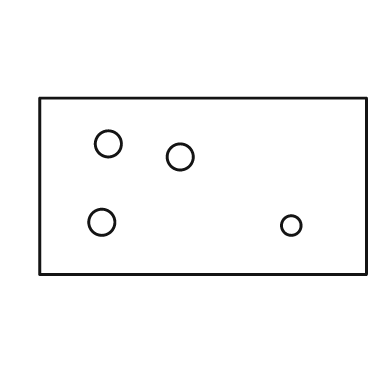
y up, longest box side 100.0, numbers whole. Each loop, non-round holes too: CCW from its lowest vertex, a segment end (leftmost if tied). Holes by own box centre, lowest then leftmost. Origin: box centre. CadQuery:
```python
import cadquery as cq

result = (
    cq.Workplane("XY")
    .moveTo(-50.0, -27.0)
    .lineTo(50.0, -27.0)
    .lineTo(50.0, 27.0)
    .lineTo(-50.0, 27.0)
    .close()
    .moveTo(27.0, -12.0)
    .circle(3.0)
    .moveTo(-31.0, -11.0)
    .circle(4.0)
    .moveTo(-7.0, 9.0)
    .circle(4.0)
    .moveTo(-29.0, 13.0)
    .circle(4.0)
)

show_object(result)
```